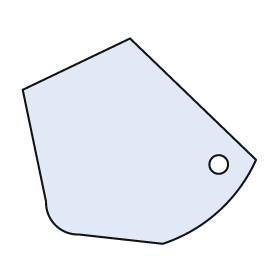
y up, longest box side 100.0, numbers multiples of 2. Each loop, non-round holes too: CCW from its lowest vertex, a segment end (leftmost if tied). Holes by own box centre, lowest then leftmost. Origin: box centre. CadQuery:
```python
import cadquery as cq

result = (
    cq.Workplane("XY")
    .moveTo(10.0, -44.0)
    .threePointArc((34.0, -30.0), (50.0, -8.0))
    .lineTo(-4.0, 44.0)
    .lineTo(-50.0, 22.0)
    .lineTo(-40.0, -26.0)
    .threePointArc((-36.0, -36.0), (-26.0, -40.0))
    .close()
    .moveTo(34.0, -10.0)
    .circle(4.0)
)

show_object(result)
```